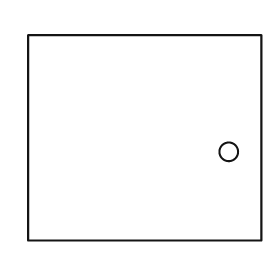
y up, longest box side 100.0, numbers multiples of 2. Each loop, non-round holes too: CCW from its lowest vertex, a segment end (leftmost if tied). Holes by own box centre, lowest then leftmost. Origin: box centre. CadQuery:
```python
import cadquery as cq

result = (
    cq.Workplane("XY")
    .moveTo(-50.0, -44.0)
    .lineTo(50.0, -44.0)
    .lineTo(50.0, 44.0)
    .lineTo(-50.0, 44.0)
    .close()
    .moveTo(36.0, -6.0)
    .circle(4.0)
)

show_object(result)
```